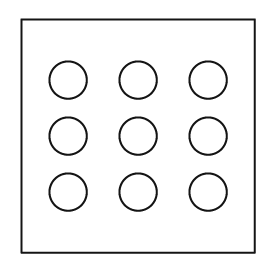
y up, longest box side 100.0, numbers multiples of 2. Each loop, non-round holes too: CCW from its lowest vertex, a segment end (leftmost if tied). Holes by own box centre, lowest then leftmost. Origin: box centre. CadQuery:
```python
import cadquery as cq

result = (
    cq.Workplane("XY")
    .moveTo(-50.0, -50.0)
    .lineTo(50.0, -50.0)
    .lineTo(50.0, 50.0)
    .lineTo(-50.0, 50.0)
    .close()
    .moveTo(-30.0, -24.0)
    .circle(8.0)
    .moveTo(0.0, -24.0)
    .circle(8.0)
    .moveTo(30.0, -24.0)
    .circle(8.0)
    .moveTo(-30.0, 0.0)
    .circle(8.0)
    .moveTo(0.0, 0.0)
    .circle(8.0)
    .moveTo(30.0, 0.0)
    .circle(8.0)
    .moveTo(-30.0, 24.0)
    .circle(8.0)
    .moveTo(0.0, 24.0)
    .circle(8.0)
    .moveTo(30.0, 24.0)
    .circle(8.0)
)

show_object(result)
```